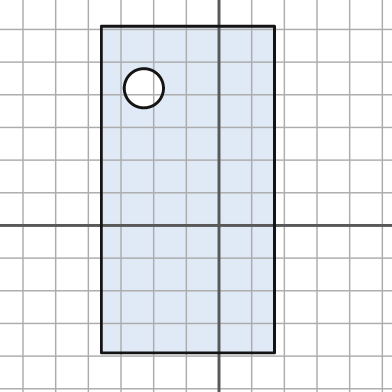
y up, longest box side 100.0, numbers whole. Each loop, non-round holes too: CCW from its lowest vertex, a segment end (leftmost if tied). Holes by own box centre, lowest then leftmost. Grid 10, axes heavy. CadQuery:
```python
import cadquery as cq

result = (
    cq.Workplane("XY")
    .moveTo(-36.0, -39.0)
    .lineTo(17.0, -39.0)
    .lineTo(17.0, 61.0)
    .lineTo(-36.0, 61.0)
    .close()
    .moveTo(-23.0, 42.0)
    .circle(6.0)
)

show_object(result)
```